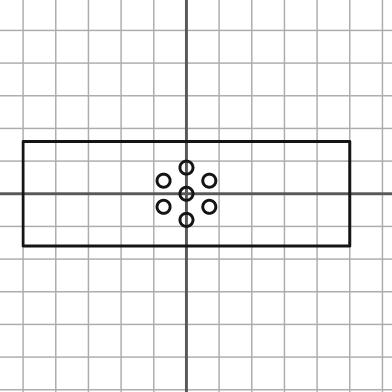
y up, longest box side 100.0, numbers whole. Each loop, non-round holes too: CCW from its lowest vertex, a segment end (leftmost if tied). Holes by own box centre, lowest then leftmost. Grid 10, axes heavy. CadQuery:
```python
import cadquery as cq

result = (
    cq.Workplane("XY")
    .moveTo(-50.0, -16.0)
    .lineTo(50.0, -16.0)
    .lineTo(50.0, 16.0)
    .lineTo(-50.0, 16.0)
    .close()
    .moveTo(0.0, -8.0)
    .circle(2.0)
    .moveTo(-7.0, -4.0)
    .circle(2.0)
    .moveTo(7.0, -4.0)
    .circle(2.0)
    .moveTo(0.0, 0.0)
    .circle(2.0)
    .moveTo(-7.0, 4.0)
    .circle(2.0)
    .moveTo(7.0, 4.0)
    .circle(2.0)
    .moveTo(0.0, 8.0)
    .circle(2.0)
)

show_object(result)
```